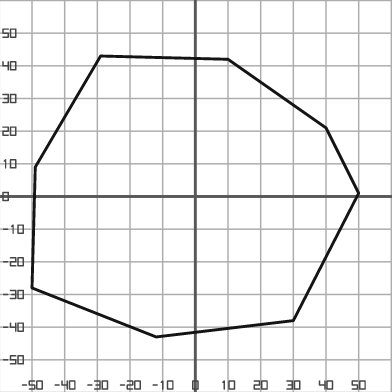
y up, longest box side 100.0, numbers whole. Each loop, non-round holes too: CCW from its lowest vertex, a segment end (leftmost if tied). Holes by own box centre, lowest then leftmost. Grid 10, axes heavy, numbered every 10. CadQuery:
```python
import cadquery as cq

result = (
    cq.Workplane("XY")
    .moveTo(-12.0, -43.0)
    .lineTo(30.0, -38.0)
    .lineTo(50.0, 1.0)
    .lineTo(40.0, 21.0)
    .lineTo(10.0, 42.0)
    .lineTo(-29.0, 43.0)
    .lineTo(-49.0, 9.0)
    .lineTo(-50.0, -28.0)
    .close()
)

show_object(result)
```